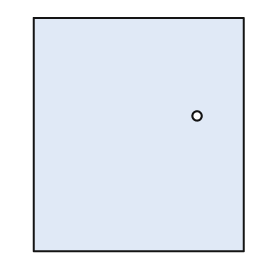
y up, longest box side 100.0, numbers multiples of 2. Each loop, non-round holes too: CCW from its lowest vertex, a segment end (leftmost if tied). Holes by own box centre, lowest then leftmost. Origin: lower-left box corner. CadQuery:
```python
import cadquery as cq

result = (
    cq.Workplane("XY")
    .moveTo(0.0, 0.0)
    .lineTo(90.0, 0.0)
    .lineTo(90.0, 100.0)
    .lineTo(0.0, 100.0)
    .close()
    .moveTo(70.0, 58.0)
    .circle(2.0)
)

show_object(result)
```